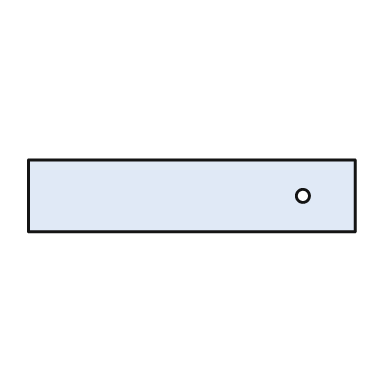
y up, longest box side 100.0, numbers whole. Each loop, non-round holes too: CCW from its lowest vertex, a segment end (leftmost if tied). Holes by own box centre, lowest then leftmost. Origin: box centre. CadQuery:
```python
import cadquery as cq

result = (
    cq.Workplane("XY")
    .moveTo(-50.0, -11.0)
    .lineTo(50.0, -11.0)
    .lineTo(50.0, 11.0)
    .lineTo(-50.0, 11.0)
    .close()
    .moveTo(34.0, 0.0)
    .circle(2.0)
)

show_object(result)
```